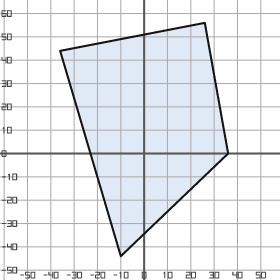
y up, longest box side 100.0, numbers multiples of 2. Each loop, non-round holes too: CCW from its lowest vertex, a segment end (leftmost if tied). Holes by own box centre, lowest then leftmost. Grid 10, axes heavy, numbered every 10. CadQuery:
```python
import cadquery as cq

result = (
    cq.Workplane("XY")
    .moveTo(-10.0, -44.0)
    .lineTo(36.0, 0.0)
    .lineTo(26.0, 56.0)
    .lineTo(-36.0, 44.0)
    .close()
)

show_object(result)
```